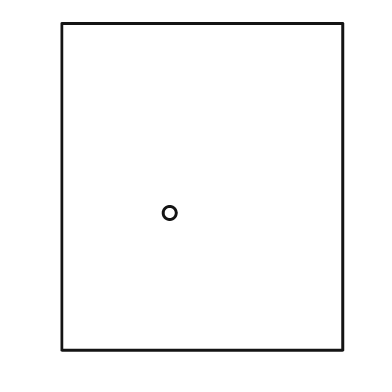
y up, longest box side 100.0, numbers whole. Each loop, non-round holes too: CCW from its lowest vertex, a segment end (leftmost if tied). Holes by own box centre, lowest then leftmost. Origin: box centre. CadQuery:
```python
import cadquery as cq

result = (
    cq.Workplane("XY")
    .moveTo(-43.0, -50.0)
    .lineTo(43.0, -50.0)
    .lineTo(43.0, 50.0)
    .lineTo(-43.0, 50.0)
    .close()
    .moveTo(-10.0, -8.0)
    .circle(2.0)
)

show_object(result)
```